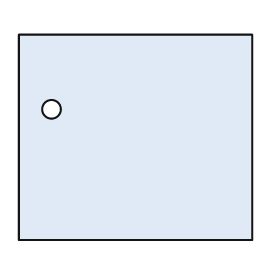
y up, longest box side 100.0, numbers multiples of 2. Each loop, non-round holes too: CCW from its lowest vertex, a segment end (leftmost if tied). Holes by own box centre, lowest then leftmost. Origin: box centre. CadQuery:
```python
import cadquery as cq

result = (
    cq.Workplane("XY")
    .moveTo(-50.0, -44.0)
    .lineTo(50.0, -44.0)
    .lineTo(50.0, 44.0)
    .lineTo(-50.0, 44.0)
    .close()
    .moveTo(-36.0, 12.0)
    .circle(4.0)
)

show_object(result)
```